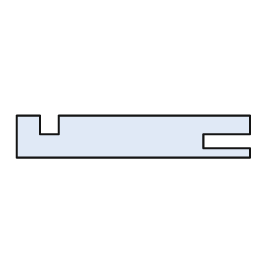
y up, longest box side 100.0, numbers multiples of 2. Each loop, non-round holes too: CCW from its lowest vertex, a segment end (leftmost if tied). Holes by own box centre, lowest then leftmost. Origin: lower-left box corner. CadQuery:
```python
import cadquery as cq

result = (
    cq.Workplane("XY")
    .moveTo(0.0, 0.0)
    .lineTo(100.0, 0.0)
    .lineTo(100.0, 4.0)
    .lineTo(80.0, 4.0)
    .lineTo(80.0, 10.0)
    .lineTo(100.0, 10.0)
    .lineTo(100.0, 18.0)
    .lineTo(18.0, 18.0)
    .lineTo(18.0, 10.0)
    .lineTo(10.0, 10.0)
    .lineTo(10.0, 18.0)
    .lineTo(0.0, 18.0)
    .close()
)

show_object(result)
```